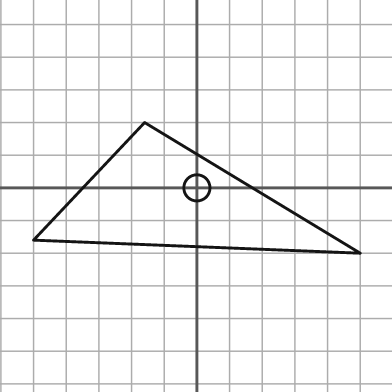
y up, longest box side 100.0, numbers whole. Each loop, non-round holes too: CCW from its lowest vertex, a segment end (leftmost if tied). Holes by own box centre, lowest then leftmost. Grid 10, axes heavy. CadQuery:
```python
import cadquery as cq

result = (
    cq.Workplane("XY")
    .moveTo(50.0, -20.0)
    .lineTo(-16.0, 20.0)
    .lineTo(-50.0, -16.0)
    .close()
    .moveTo(0.0, 0.0)
    .circle(4.0)
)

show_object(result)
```